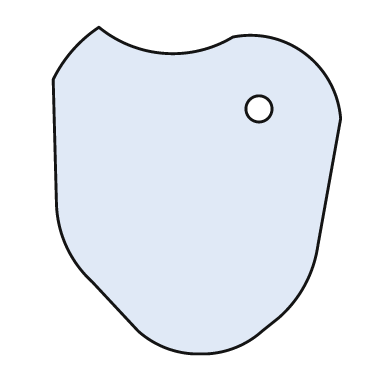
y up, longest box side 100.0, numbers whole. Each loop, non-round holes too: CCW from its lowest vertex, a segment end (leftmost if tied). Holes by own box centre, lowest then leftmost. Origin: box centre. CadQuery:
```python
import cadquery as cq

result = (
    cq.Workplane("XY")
    .moveTo(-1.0, -50.0)
    .lineTo(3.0, -50.0)
    .threePointArc((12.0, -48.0), (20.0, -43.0))
    .lineTo(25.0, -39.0)
    .threePointArc((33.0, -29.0), (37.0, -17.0))
    .lineTo(44.0, 22.0)
    .threePointArc((33.0, 42.0), (11.0, 47.0))
    .threePointArc((-10.0, 42.0), (-30.0, 50.0))
    .threePointArc((-38.0, 43.0), (-44.0, 34.0))
    .lineTo(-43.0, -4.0)
    .threePointArc((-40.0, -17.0), (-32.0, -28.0))
    .lineTo(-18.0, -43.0)
    .threePointArc((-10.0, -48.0), (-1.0, -50.0))
    .close()
    .moveTo(19.0, 25.0)
    .circle(4.0)
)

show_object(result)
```